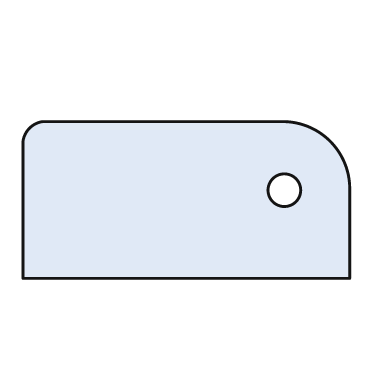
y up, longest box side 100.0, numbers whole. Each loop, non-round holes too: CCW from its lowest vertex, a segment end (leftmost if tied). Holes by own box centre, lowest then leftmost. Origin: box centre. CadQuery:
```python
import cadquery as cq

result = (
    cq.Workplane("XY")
    .moveTo(-50.0, -24.0)
    .lineTo(50.0, -24.0)
    .lineTo(50.0, 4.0)
    .threePointArc((44.0, 18.0), (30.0, 24.0))
    .lineTo(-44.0, 24.0)
    .threePointArc((-48.0, 22.0), (-50.0, 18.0))
    .close()
    .moveTo(30.0, 3.0)
    .circle(5.0)
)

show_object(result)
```